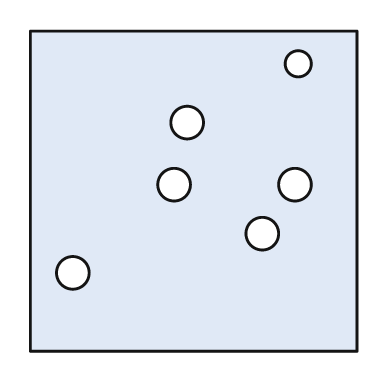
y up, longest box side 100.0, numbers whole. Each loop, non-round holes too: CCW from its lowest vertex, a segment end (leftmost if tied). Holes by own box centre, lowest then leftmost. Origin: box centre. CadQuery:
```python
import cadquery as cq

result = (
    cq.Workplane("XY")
    .moveTo(-50.0, -49.0)
    .lineTo(50.0, -49.0)
    .lineTo(50.0, 49.0)
    .lineTo(-50.0, 49.0)
    .close()
    .moveTo(-37.0, -25.0)
    .circle(5.0)
    .moveTo(21.0, -13.0)
    .circle(5.0)
    .moveTo(-6.0, 2.0)
    .circle(5.0)
    .moveTo(31.0, 2.0)
    .circle(5.0)
    .moveTo(-2.0, 21.0)
    .circle(5.0)
    .moveTo(32.0, 39.0)
    .circle(4.0)
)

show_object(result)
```